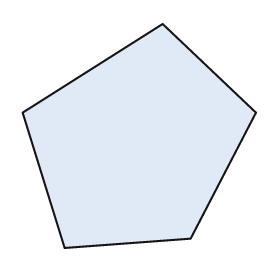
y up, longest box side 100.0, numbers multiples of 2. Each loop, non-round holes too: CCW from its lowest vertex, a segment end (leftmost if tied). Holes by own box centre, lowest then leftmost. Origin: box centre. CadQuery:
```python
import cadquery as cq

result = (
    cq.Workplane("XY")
    .moveTo(-32.0, -48.0)
    .lineTo(22.0, -44.0)
    .lineTo(50.0, 10.0)
    .lineTo(10.0, 48.0)
    .lineTo(-50.0, 10.0)
    .close()
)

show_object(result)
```